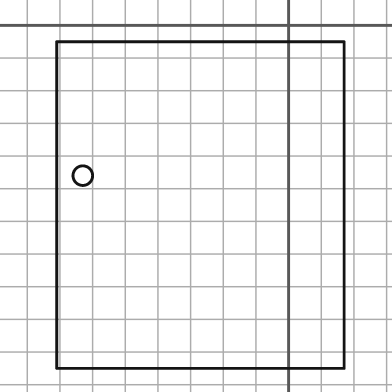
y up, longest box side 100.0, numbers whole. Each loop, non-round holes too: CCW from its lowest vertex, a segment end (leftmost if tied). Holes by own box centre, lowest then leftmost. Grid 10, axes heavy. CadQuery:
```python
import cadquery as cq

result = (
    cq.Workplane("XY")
    .moveTo(-71.0, -105.0)
    .lineTo(17.0, -105.0)
    .lineTo(17.0, -5.0)
    .lineTo(-71.0, -5.0)
    .close()
    .moveTo(-63.0, -46.0)
    .circle(3.0)
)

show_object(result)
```